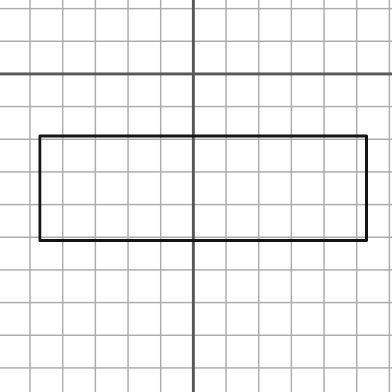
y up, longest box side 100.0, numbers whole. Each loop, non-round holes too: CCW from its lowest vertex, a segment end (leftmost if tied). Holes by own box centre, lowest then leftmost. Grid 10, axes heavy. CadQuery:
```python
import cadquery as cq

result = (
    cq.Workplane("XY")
    .moveTo(-47.0, -51.0)
    .lineTo(53.0, -51.0)
    .lineTo(53.0, -19.0)
    .lineTo(-47.0, -19.0)
    .close()
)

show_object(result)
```